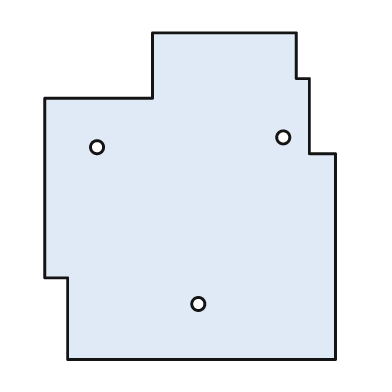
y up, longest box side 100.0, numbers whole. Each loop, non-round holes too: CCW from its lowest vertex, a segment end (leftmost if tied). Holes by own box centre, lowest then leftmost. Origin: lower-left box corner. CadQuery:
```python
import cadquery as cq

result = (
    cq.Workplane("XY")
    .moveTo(7.0, 0.0)
    .lineTo(89.0, 0.0)
    .lineTo(89.0, 63.0)
    .lineTo(81.0, 63.0)
    .lineTo(81.0, 86.0)
    .lineTo(77.0, 86.0)
    .lineTo(77.0, 100.0)
    .lineTo(33.0, 100.0)
    .lineTo(33.0, 80.0)
    .lineTo(0.0, 80.0)
    .lineTo(0.0, 25.0)
    .lineTo(7.0, 25.0)
    .close()
    .moveTo(47.0, 17.0)
    .circle(2.0)
    .moveTo(16.0, 65.0)
    .circle(2.0)
    .moveTo(73.0, 68.0)
    .circle(2.0)
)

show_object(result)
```